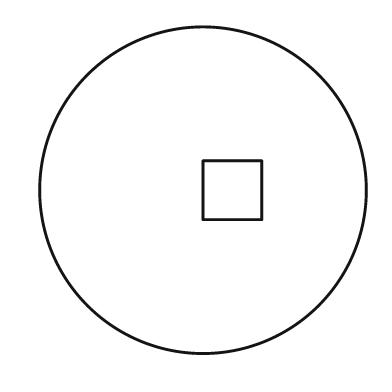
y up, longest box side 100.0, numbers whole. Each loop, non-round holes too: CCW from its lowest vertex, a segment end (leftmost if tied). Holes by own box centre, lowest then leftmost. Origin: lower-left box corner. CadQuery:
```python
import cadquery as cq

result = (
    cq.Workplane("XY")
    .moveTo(50.0, 50.0)
    .circle(50.0)
    .moveTo(50.0, 41.0)
    .lineTo(68.0, 41.0)
    .lineTo(68.0, 59.0)
    .lineTo(50.0, 59.0)
    .close()
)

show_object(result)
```